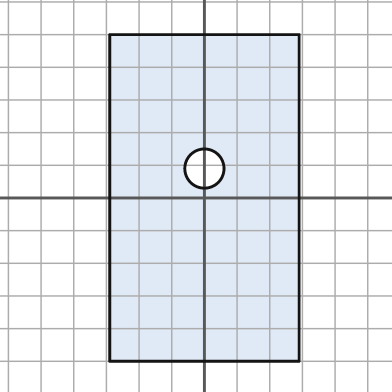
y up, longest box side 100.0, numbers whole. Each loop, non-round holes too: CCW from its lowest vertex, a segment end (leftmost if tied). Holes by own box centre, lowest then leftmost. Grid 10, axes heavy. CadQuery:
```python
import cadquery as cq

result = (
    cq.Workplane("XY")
    .moveTo(-29.0, -50.0)
    .lineTo(29.0, -50.0)
    .lineTo(29.0, 50.0)
    .lineTo(-29.0, 50.0)
    .close()
    .moveTo(0.0, 9.0)
    .circle(6.0)
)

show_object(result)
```